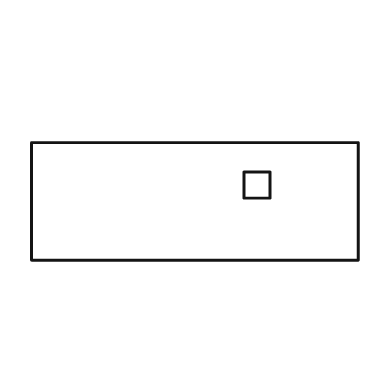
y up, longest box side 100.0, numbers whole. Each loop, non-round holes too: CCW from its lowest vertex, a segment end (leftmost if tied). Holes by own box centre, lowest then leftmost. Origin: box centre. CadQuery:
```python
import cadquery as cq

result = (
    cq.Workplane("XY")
    .moveTo(-50.0, -18.0)
    .lineTo(50.0, -18.0)
    .lineTo(50.0, 18.0)
    .lineTo(-50.0, 18.0)
    .close()
    .moveTo(15.0, 1.0)
    .lineTo(23.0, 1.0)
    .lineTo(23.0, 9.0)
    .lineTo(15.0, 9.0)
    .close()
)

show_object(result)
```